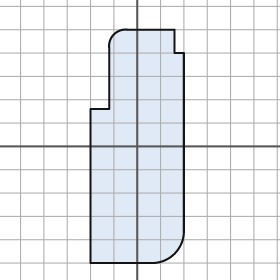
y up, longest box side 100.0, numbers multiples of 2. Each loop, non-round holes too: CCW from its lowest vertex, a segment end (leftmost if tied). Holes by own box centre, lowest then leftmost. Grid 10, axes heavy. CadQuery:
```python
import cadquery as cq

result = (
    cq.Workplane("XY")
    .moveTo(-20.0, -50.0)
    .lineTo(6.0, -50.0)
    .threePointArc((16.0, -46.0), (20.0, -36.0))
    .lineTo(20.0, 40.0)
    .lineTo(16.0, 40.0)
    .lineTo(16.0, 50.0)
    .lineTo(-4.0, 50.0)
    .threePointArc((-10.0, 48.0), (-12.0, 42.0))
    .lineTo(-12.0, 16.0)
    .lineTo(-20.0, 16.0)
    .close()
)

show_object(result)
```